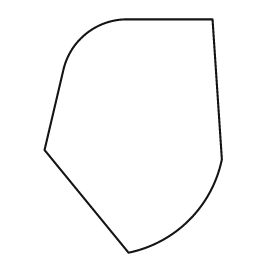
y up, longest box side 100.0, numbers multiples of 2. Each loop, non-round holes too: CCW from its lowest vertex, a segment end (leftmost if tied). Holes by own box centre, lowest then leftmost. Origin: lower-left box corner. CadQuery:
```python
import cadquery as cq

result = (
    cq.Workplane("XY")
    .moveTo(36.0, 0.0)
    .threePointArc((62.0, 14.0), (76.0, 40.0))
    .lineTo(72.0, 100.0)
    .lineTo(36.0, 100.0)
    .threePointArc((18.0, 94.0), (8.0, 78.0))
    .lineTo(0.0, 44.0)
    .close()
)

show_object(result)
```